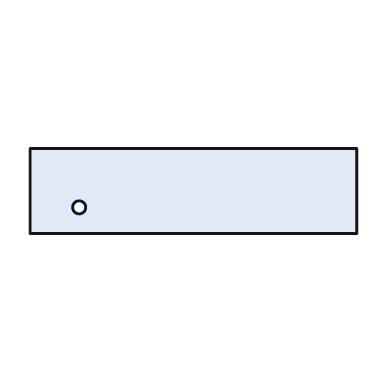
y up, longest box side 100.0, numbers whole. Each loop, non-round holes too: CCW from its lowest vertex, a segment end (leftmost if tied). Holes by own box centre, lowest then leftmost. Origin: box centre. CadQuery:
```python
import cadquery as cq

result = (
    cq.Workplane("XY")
    .moveTo(-50.0, -13.0)
    .lineTo(50.0, -13.0)
    .lineTo(50.0, 13.0)
    .lineTo(-50.0, 13.0)
    .close()
    .moveTo(-35.0, -5.0)
    .circle(2.0)
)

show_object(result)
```